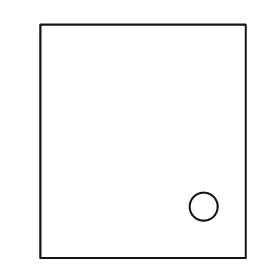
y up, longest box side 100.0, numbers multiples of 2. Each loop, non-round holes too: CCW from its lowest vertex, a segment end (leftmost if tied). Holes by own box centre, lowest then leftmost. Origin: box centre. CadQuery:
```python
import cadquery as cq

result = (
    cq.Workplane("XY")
    .moveTo(-44.0, -50.0)
    .lineTo(44.0, -50.0)
    .lineTo(44.0, 50.0)
    .lineTo(-44.0, 50.0)
    .close()
    .moveTo(26.0, -28.0)
    .circle(6.0)
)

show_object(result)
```